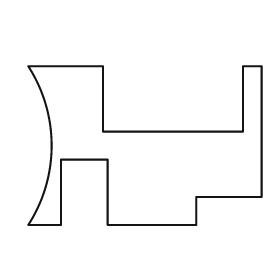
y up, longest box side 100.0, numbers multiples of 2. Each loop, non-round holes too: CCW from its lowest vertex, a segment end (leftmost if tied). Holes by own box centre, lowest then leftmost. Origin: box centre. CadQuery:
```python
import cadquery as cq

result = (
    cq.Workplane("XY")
    .moveTo(-50.0, -34.0)
    .lineTo(-36.0, -34.0)
    .lineTo(-36.0, -6.0)
    .lineTo(-16.0, -6.0)
    .lineTo(-16.0, -34.0)
    .lineTo(22.0, -34.0)
    .lineTo(22.0, -22.0)
    .lineTo(50.0, -22.0)
    .lineTo(50.0, 34.0)
    .lineTo(42.0, 34.0)
    .lineTo(42.0, 6.0)
    .lineTo(-18.0, 6.0)
    .lineTo(-18.0, 34.0)
    .lineTo(-50.0, 34.0)
    .threePointArc((-40.0, 0.0), (-50.0, -34.0))
    .close()
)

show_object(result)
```